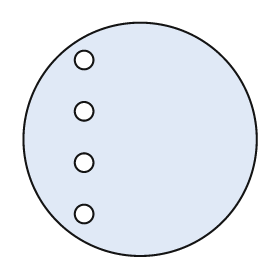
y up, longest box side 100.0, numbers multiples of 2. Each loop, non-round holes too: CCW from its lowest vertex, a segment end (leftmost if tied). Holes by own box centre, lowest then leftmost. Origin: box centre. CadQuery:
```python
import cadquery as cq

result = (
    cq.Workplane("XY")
    .moveTo(0.0, 0.0)
    .circle(50.0)
    .moveTo(-24.0, -32.0)
    .circle(4.0)
    .moveTo(-24.0, -10.0)
    .circle(4.0)
    .moveTo(-24.0, 12.0)
    .circle(4.0)
    .moveTo(-24.0, 34.0)
    .circle(4.0)
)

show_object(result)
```